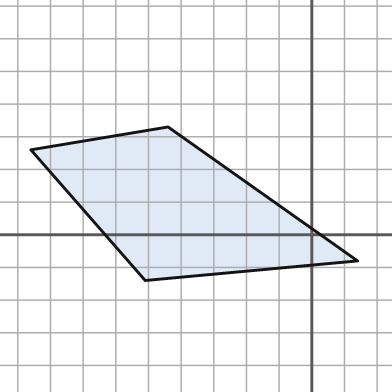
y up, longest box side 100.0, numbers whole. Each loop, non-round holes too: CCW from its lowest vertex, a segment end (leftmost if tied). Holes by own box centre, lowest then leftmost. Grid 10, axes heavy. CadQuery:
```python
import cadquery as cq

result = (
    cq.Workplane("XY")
    .moveTo(-51.0, -14.0)
    .lineTo(14.0, -8.0)
    .lineTo(-44.0, 33.0)
    .lineTo(-86.0, 26.0)
    .close()
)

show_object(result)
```